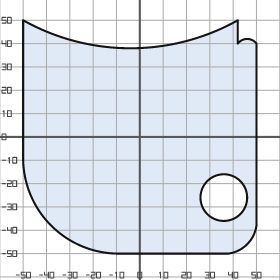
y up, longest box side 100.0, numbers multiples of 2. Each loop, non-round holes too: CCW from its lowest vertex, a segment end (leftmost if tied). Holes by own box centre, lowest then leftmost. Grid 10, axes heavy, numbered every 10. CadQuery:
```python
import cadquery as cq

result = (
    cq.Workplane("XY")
    .moveTo(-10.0, -50.0)
    .lineTo(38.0, -50.0)
    .threePointArc((46.0, -46.0), (50.0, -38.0))
    .lineTo(50.0, 40.0)
    .threePointArc((46.0, 42.0), (42.0, 40.0))
    .lineTo(42.0, 50.0)
    .threePointArc((-4.0, 38.0), (-50.0, 50.0))
    .lineTo(-50.0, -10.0)
    .threePointArc((-38.0, -38.0), (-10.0, -50.0))
    .close()
    .moveTo(36.0, -26.0)
    .circle(10.0)
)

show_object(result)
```